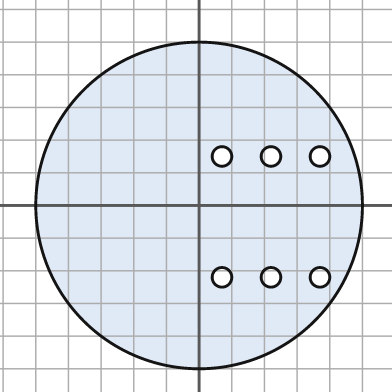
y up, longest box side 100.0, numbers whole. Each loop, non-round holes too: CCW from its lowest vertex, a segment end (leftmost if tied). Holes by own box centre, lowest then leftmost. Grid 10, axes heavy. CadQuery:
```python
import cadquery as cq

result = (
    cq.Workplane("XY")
    .moveTo(0.0, 0.0)
    .circle(50.0)
    .moveTo(7.0, -22.0)
    .circle(3.0)
    .moveTo(22.0, -22.0)
    .circle(3.0)
    .moveTo(37.0, -22.0)
    .circle(3.0)
    .moveTo(7.0, 15.0)
    .circle(3.0)
    .moveTo(22.0, 15.0)
    .circle(3.0)
    .moveTo(37.0, 15.0)
    .circle(3.0)
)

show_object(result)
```